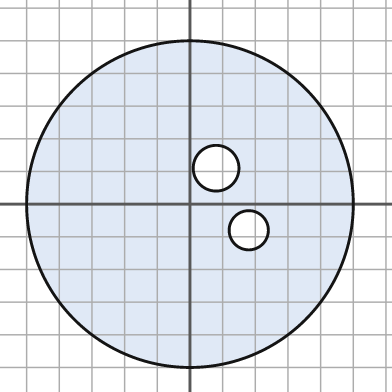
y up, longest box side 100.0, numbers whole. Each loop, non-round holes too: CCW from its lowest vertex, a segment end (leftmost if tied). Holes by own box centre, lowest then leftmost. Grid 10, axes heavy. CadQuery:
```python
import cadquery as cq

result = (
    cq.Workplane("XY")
    .moveTo(0.0, 0.0)
    .circle(50.0)
    .moveTo(18.0, -8.0)
    .circle(6.0)
    .moveTo(8.0, 11.0)
    .circle(7.0)
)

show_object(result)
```